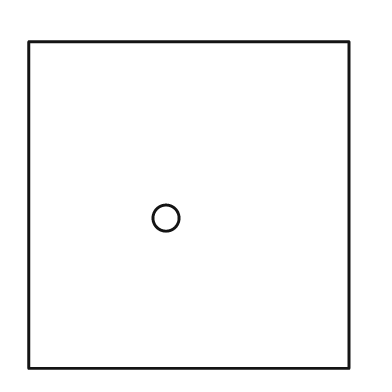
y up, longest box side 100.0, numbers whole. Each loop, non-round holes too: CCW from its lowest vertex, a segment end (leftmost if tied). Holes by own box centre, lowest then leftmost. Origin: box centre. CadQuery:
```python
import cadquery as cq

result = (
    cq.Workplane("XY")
    .moveTo(-49.0, -50.0)
    .lineTo(49.0, -50.0)
    .lineTo(49.0, 50.0)
    .lineTo(-49.0, 50.0)
    .close()
    .moveTo(-7.0, -4.0)
    .circle(4.0)
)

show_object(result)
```